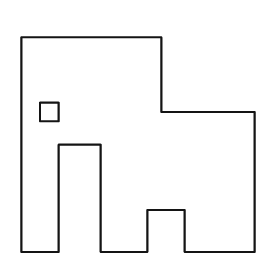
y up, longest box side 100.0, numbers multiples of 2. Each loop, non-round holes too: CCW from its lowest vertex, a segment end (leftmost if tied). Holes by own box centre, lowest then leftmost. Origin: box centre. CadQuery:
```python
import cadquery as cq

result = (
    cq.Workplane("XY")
    .moveTo(-50.0, -46.0)
    .lineTo(-34.0, -46.0)
    .lineTo(-34.0, 0.0)
    .lineTo(-16.0, 0.0)
    .lineTo(-16.0, -46.0)
    .lineTo(4.0, -46.0)
    .lineTo(4.0, -28.0)
    .lineTo(20.0, -28.0)
    .lineTo(20.0, -46.0)
    .lineTo(50.0, -46.0)
    .lineTo(50.0, 14.0)
    .lineTo(10.0, 14.0)
    .lineTo(10.0, 46.0)
    .lineTo(-50.0, 46.0)
    .close()
    .moveTo(-42.0, 10.0)
    .lineTo(-34.0, 10.0)
    .lineTo(-34.0, 18.0)
    .lineTo(-42.0, 18.0)
    .close()
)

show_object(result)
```